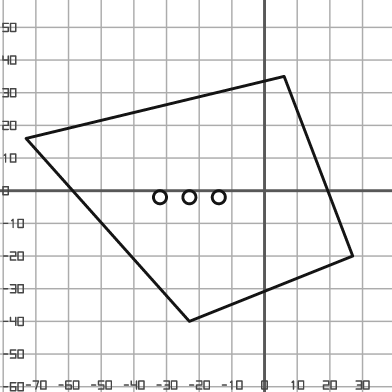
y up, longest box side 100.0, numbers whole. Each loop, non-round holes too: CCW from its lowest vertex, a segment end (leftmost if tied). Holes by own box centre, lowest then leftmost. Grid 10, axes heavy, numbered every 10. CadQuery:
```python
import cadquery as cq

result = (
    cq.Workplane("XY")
    .moveTo(-23.0, -40.0)
    .lineTo(27.0, -20.0)
    .lineTo(6.0, 35.0)
    .lineTo(-73.0, 16.0)
    .close()
    .moveTo(-32.0, -2.0)
    .circle(2.0)
    .moveTo(-23.0, -2.0)
    .circle(2.0)
    .moveTo(-14.0, -2.0)
    .circle(2.0)
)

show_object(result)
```